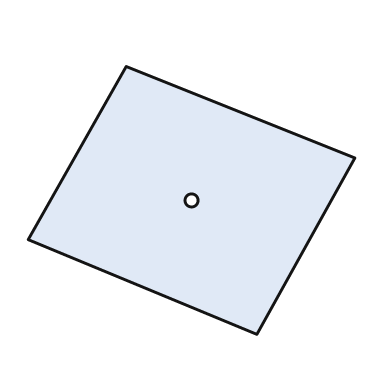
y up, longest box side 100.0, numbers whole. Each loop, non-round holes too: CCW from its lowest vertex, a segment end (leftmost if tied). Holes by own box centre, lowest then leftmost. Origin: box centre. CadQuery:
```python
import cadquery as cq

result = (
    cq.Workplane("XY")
    .moveTo(20.0, -41.0)
    .lineTo(50.0, 13.0)
    .lineTo(-20.0, 41.0)
    .lineTo(-50.0, -12.0)
    .close()
    .moveTo(0.0, 0.0)
    .circle(2.0)
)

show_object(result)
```